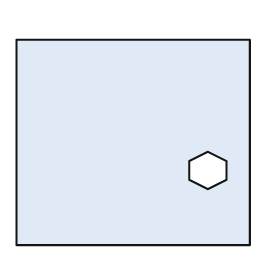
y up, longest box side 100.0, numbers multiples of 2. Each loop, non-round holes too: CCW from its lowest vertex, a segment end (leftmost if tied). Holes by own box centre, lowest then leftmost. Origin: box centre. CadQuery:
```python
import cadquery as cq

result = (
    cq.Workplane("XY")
    .moveTo(-50.0, -44.0)
    .lineTo(50.0, -44.0)
    .lineTo(50.0, 44.0)
    .lineTo(-50.0, 44.0)
    .close()
    .moveTo(32.0, -20.0)
    .lineTo(40.0, -16.0)
    .lineTo(40.0, -8.0)
    .lineTo(32.0, -4.0)
    .lineTo(24.0, -8.0)
    .lineTo(24.0, -16.0)
    .close()
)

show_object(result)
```